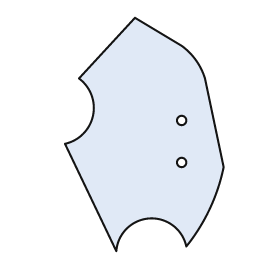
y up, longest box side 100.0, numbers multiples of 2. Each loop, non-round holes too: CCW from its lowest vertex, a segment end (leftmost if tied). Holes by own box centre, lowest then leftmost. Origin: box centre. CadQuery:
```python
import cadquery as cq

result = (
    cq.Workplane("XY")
    .moveTo(-12.0, -50.0)
    .threePointArc((2.0, -36.0), (18.0, -48.0))
    .threePointArc((28.0, -32.0), (34.0, -14.0))
    .lineTo(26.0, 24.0)
    .threePointArc((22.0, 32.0), (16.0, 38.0))
    .lineTo(-4.0, 50.0)
    .lineTo(-28.0, 24.0)
    .threePointArc((-22.0, 8.0), (-34.0, -4.0))
    .close()
    .moveTo(16.0, -12.0)
    .circle(2.0)
    .moveTo(16.0, 6.0)
    .circle(2.0)
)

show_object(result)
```